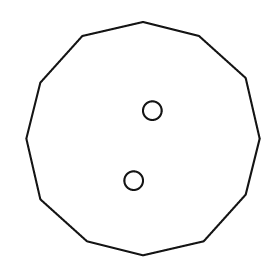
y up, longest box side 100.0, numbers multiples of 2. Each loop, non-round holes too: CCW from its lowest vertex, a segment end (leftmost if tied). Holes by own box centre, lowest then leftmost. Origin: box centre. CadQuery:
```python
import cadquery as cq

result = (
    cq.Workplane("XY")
    .moveTo(0.0, -50.0)
    .lineTo(26.0, -44.0)
    .lineTo(44.0, -24.0)
    .lineTo(50.0, 0.0)
    .lineTo(44.0, 26.0)
    .lineTo(24.0, 44.0)
    .lineTo(0.0, 50.0)
    .lineTo(-26.0, 44.0)
    .lineTo(-44.0, 24.0)
    .lineTo(-50.0, 0.0)
    .lineTo(-44.0, -26.0)
    .lineTo(-24.0, -44.0)
    .close()
    .moveTo(-4.0, -18.0)
    .circle(4.0)
    .moveTo(4.0, 12.0)
    .circle(4.0)
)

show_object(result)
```